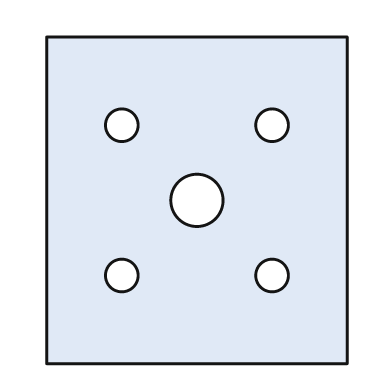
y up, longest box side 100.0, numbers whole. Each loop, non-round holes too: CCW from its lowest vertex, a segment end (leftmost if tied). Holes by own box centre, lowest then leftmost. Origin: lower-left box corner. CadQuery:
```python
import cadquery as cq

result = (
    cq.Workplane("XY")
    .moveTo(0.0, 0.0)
    .lineTo(92.0, 0.0)
    .lineTo(92.0, 100.0)
    .lineTo(0.0, 100.0)
    .close()
    .moveTo(23.0, 27.0)
    .circle(5.0)
    .moveTo(69.0, 27.0)
    .circle(5.0)
    .moveTo(46.0, 50.0)
    .circle(8.0)
    .moveTo(23.0, 73.0)
    .circle(5.0)
    .moveTo(69.0, 73.0)
    .circle(5.0)
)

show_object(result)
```